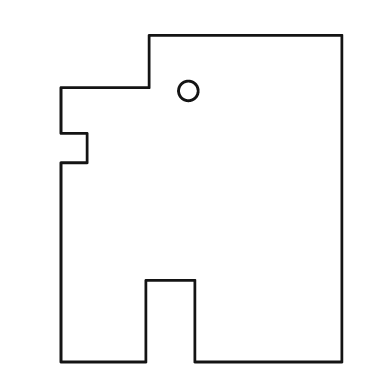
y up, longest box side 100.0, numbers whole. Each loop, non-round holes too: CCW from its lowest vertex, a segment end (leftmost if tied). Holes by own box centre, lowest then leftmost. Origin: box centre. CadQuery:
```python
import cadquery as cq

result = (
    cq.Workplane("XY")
    .moveTo(-43.0, -50.0)
    .lineTo(-17.0, -50.0)
    .lineTo(-17.0, -25.0)
    .lineTo(-2.0, -25.0)
    .lineTo(-2.0, -50.0)
    .lineTo(43.0, -50.0)
    .lineTo(43.0, 50.0)
    .lineTo(-16.0, 50.0)
    .lineTo(-16.0, 34.0)
    .lineTo(-43.0, 34.0)
    .lineTo(-43.0, 20.0)
    .lineTo(-35.0, 20.0)
    .lineTo(-35.0, 11.0)
    .lineTo(-43.0, 11.0)
    .close()
    .moveTo(-4.0, 33.0)
    .circle(3.0)
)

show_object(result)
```